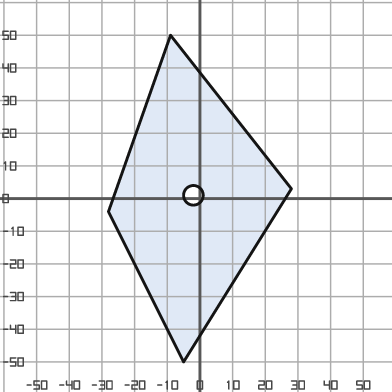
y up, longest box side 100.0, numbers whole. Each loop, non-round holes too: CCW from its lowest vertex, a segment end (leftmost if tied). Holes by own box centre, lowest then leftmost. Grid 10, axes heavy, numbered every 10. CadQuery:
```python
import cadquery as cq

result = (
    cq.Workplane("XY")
    .moveTo(-5.0, -50.0)
    .lineTo(28.0, 3.0)
    .lineTo(-9.0, 50.0)
    .lineTo(-28.0, -4.0)
    .close()
    .moveTo(-2.0, 1.0)
    .circle(3.0)
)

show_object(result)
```